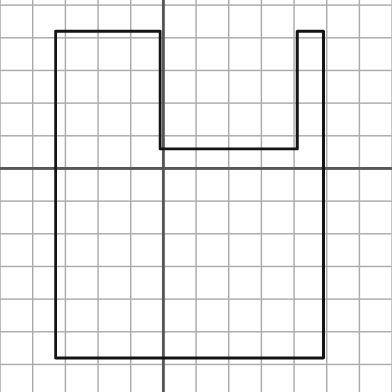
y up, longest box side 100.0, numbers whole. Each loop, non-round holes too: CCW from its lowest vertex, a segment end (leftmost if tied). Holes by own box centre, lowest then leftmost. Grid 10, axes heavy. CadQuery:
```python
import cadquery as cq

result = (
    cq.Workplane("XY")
    .moveTo(-33.0, -58.0)
    .lineTo(49.0, -58.0)
    .lineTo(49.0, 42.0)
    .lineTo(41.0, 42.0)
    .lineTo(41.0, 6.0)
    .lineTo(-1.0, 6.0)
    .lineTo(-1.0, 42.0)
    .lineTo(-33.0, 42.0)
    .close()
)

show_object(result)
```